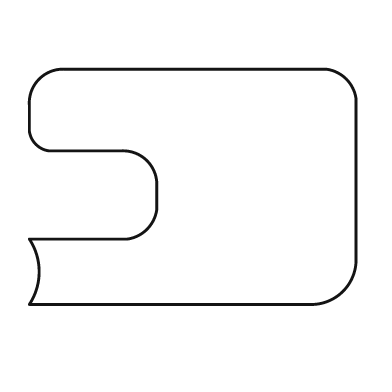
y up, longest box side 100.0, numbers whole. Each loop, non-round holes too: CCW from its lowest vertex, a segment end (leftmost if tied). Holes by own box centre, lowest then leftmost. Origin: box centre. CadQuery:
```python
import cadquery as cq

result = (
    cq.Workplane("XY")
    .moveTo(-50.0, -36.0)
    .lineTo(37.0, -36.0)
    .threePointArc((46.0, -32.0), (50.0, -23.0))
    .lineTo(50.0, 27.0)
    .threePointArc((47.0, 33.0), (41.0, 36.0))
    .lineTo(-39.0, 36.0)
    .threePointArc((-47.0, 33.0), (-50.0, 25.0))
    .lineTo(-50.0, 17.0)
    .threePointArc((-48.0, 13.0), (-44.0, 11.0))
    .lineTo(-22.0, 11.0)
    .threePointArc((-14.0, 8.0), (-11.0, 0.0))
    .lineTo(-11.0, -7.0)
    .threePointArc((-14.0, -13.0), (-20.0, -16.0))
    .lineTo(-50.0, -16.0)
    .threePointArc((-47.0, -26.0), (-50.0, -36.0))
    .close()
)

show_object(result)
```